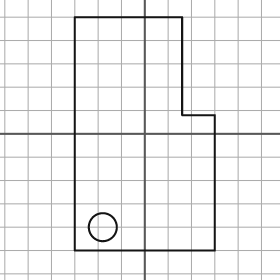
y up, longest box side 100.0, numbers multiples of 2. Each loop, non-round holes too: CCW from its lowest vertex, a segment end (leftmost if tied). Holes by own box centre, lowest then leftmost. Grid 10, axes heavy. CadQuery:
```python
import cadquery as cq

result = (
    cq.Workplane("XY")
    .moveTo(-30.0, -50.0)
    .lineTo(30.0, -50.0)
    .lineTo(30.0, 8.0)
    .lineTo(16.0, 8.0)
    .lineTo(16.0, 50.0)
    .lineTo(-30.0, 50.0)
    .close()
    .moveTo(-18.0, -40.0)
    .circle(6.0)
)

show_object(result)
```